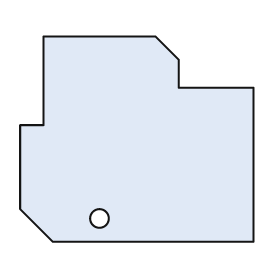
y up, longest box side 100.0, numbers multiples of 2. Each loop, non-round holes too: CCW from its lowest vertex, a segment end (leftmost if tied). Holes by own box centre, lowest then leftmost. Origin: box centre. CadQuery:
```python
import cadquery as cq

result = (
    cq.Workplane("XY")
    .moveTo(-36.0, -44.0)
    .lineTo(50.0, -44.0)
    .lineTo(50.0, 22.0)
    .lineTo(18.0, 22.0)
    .lineTo(18.0, 34.0)
    .lineTo(8.0, 44.0)
    .lineTo(-40.0, 44.0)
    .lineTo(-40.0, 6.0)
    .lineTo(-50.0, 6.0)
    .lineTo(-50.0, -30.0)
    .close()
    .moveTo(-16.0, -34.0)
    .circle(4.0)
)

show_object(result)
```